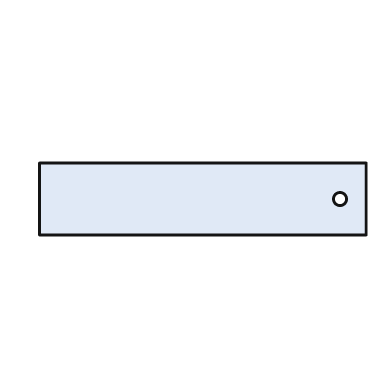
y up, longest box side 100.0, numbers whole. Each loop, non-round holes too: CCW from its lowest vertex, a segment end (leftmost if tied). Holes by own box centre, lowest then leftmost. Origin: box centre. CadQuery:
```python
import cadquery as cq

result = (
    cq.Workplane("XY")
    .moveTo(-50.0, -11.0)
    .lineTo(50.0, -11.0)
    .lineTo(50.0, 11.0)
    .lineTo(-50.0, 11.0)
    .close()
    .moveTo(42.0, 0.0)
    .circle(2.0)
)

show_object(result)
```